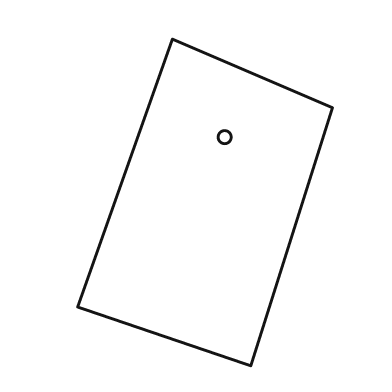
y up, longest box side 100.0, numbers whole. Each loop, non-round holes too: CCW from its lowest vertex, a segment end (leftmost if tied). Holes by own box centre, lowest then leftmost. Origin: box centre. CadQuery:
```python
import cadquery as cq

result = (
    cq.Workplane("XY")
    .moveTo(14.0, -50.0)
    .lineTo(39.0, 29.0)
    .lineTo(-10.0, 50.0)
    .lineTo(-39.0, -32.0)
    .close()
    .moveTo(6.0, 20.0)
    .circle(2.0)
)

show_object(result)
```